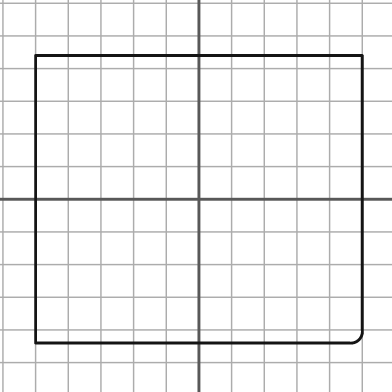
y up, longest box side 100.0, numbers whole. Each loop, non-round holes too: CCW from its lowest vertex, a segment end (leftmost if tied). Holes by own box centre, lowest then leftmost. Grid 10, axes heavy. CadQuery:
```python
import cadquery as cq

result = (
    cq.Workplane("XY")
    .moveTo(-50.0, -44.0)
    .lineTo(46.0, -44.0)
    .threePointArc((49.0, -43.0), (50.0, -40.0))
    .lineTo(50.0, 44.0)
    .lineTo(-50.0, 44.0)
    .close()
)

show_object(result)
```